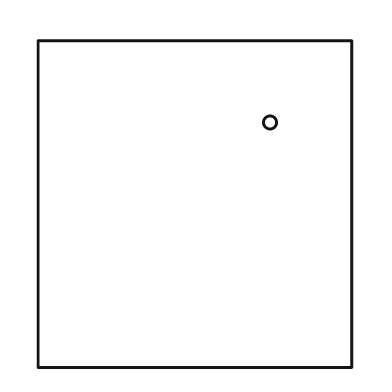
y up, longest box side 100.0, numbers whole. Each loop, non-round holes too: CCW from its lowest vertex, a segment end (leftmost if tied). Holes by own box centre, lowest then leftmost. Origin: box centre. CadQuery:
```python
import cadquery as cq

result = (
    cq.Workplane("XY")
    .moveTo(-48.0, -50.0)
    .lineTo(48.0, -50.0)
    .lineTo(48.0, 50.0)
    .lineTo(-48.0, 50.0)
    .close()
    .moveTo(23.0, 25.0)
    .circle(2.0)
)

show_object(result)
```